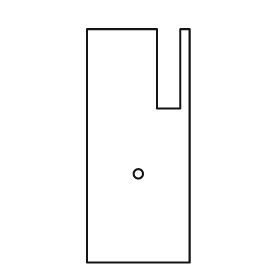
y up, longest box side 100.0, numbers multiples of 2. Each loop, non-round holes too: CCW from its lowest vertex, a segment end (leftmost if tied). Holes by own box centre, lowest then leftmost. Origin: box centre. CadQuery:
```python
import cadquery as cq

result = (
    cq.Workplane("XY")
    .moveTo(-22.0, -50.0)
    .lineTo(22.0, -50.0)
    .lineTo(22.0, 50.0)
    .lineTo(18.0, 50.0)
    .lineTo(18.0, 16.0)
    .lineTo(8.0, 16.0)
    .lineTo(8.0, 50.0)
    .lineTo(-22.0, 50.0)
    .close()
    .moveTo(0.0, -12.0)
    .circle(2.0)
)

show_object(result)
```